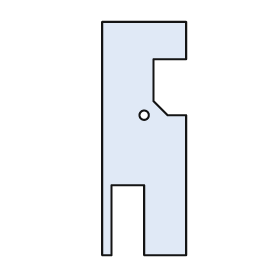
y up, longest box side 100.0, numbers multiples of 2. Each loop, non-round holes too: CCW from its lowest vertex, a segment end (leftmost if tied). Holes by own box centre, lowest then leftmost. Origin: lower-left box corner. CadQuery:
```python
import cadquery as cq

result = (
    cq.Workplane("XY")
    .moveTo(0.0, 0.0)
    .lineTo(4.0, 0.0)
    .lineTo(4.0, 30.0)
    .lineTo(18.0, 30.0)
    .lineTo(18.0, 0.0)
    .lineTo(36.0, 0.0)
    .lineTo(36.0, 60.0)
    .lineTo(28.0, 60.0)
    .lineTo(22.0, 66.0)
    .lineTo(22.0, 84.0)
    .lineTo(36.0, 84.0)
    .lineTo(36.0, 100.0)
    .lineTo(0.0, 100.0)
    .close()
    .moveTo(18.0, 60.0)
    .circle(2.0)
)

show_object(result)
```